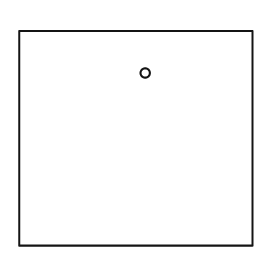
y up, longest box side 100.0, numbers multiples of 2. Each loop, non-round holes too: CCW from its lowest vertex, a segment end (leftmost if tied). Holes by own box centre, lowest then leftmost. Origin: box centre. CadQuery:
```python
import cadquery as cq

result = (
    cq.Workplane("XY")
    .moveTo(-50.0, -46.0)
    .lineTo(50.0, -46.0)
    .lineTo(50.0, 46.0)
    .lineTo(-50.0, 46.0)
    .close()
    .moveTo(4.0, 28.0)
    .circle(2.0)
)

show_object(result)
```